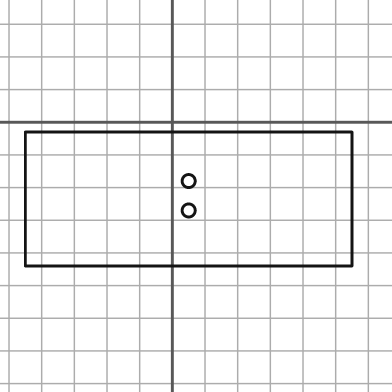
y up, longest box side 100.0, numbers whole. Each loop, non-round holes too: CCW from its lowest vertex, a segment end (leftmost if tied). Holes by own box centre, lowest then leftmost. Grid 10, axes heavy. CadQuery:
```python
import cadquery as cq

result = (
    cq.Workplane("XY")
    .moveTo(-45.0, -44.0)
    .lineTo(55.0, -44.0)
    .lineTo(55.0, -3.0)
    .lineTo(-45.0, -3.0)
    .close()
    .moveTo(5.0, -27.0)
    .circle(2.0)
    .moveTo(5.0, -18.0)
    .circle(2.0)
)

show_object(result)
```